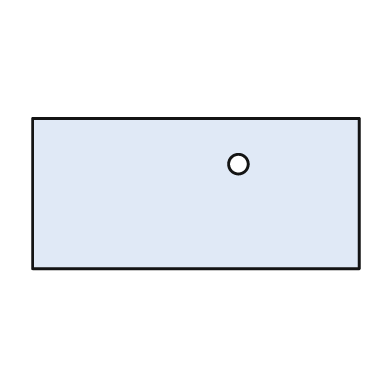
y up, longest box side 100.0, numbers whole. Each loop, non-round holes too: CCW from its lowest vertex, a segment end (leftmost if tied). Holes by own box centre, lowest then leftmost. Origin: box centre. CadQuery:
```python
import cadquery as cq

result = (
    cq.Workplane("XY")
    .moveTo(-50.0, -23.0)
    .lineTo(50.0, -23.0)
    .lineTo(50.0, 23.0)
    .lineTo(-50.0, 23.0)
    .close()
    .moveTo(13.0, 9.0)
    .circle(3.0)
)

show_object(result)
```